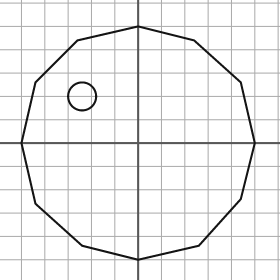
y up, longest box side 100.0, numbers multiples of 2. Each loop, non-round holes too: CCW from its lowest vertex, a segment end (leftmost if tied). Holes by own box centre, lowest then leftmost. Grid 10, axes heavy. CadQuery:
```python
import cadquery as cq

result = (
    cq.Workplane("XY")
    .moveTo(0.0, -50.0)
    .lineTo(26.0, -44.0)
    .lineTo(44.0, -24.0)
    .lineTo(50.0, 0.0)
    .lineTo(44.0, 26.0)
    .lineTo(24.0, 44.0)
    .lineTo(0.0, 50.0)
    .lineTo(-26.0, 44.0)
    .lineTo(-44.0, 26.0)
    .lineTo(-50.0, 0.0)
    .lineTo(-44.0, -26.0)
    .lineTo(-24.0, -44.0)
    .close()
    .moveTo(-24.0, 20.0)
    .circle(6.0)
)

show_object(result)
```